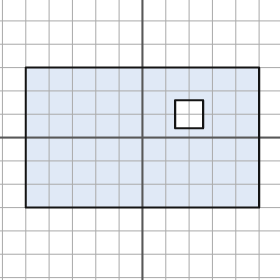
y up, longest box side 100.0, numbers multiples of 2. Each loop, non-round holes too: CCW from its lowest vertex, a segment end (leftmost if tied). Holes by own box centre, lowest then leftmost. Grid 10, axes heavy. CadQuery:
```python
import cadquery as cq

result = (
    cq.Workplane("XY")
    .moveTo(-50.0, -30.0)
    .lineTo(50.0, -30.0)
    .lineTo(50.0, 30.0)
    .lineTo(-50.0, 30.0)
    .close()
    .moveTo(14.0, 4.0)
    .lineTo(26.0, 4.0)
    .lineTo(26.0, 16.0)
    .lineTo(14.0, 16.0)
    .close()
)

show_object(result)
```